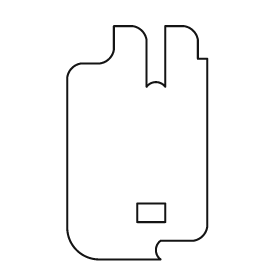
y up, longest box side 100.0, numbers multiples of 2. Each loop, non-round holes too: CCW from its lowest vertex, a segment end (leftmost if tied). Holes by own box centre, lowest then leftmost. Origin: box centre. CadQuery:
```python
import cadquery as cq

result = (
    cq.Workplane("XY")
    .moveTo(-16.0, -50.0)
    .lineTo(10.0, -50.0)
    .threePointArc((8.0, -46.0), (10.0, -42.0))
    .lineTo(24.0, -42.0)
    .threePointArc((28.0, -40.0), (30.0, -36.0))
    .lineTo(30.0, 36.0)
    .lineTo(26.0, 36.0)
    .lineTo(26.0, 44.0)
    .threePointArc((24.0, 48.0), (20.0, 50.0))
    .lineTo(12.0, 50.0)
    .lineTo(12.0, 24.0)
    .threePointArc((8.0, 26.0), (4.0, 24.0))
    .lineTo(4.0, 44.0)
    .threePointArc((2.0, 48.0), (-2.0, 50.0))
    .lineTo(-10.0, 50.0)
    .lineTo(-10.0, 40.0)
    .threePointArc((-12.0, 36.0), (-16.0, 34.0))
    .lineTo(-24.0, 34.0)
    .threePointArc((-28.0, 32.0), (-30.0, 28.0))
    .lineTo(-30.0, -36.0)
    .threePointArc((-26.0, -46.0), (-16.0, -50.0))
    .close()
    .moveTo(0.0, -34.0)
    .lineTo(12.0, -34.0)
    .lineTo(12.0, -26.0)
    .lineTo(0.0, -26.0)
    .close()
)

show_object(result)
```